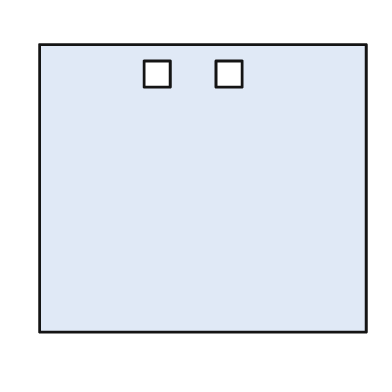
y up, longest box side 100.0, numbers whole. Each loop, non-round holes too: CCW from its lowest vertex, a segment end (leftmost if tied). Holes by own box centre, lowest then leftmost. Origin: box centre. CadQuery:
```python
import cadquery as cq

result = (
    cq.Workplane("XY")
    .moveTo(-50.0, -44.0)
    .lineTo(50.0, -44.0)
    .lineTo(50.0, 44.0)
    .lineTo(-50.0, 44.0)
    .close()
    .moveTo(-18.0, 31.0)
    .lineTo(-10.0, 31.0)
    .lineTo(-10.0, 39.0)
    .lineTo(-18.0, 39.0)
    .close()
    .moveTo(4.0, 31.0)
    .lineTo(12.0, 31.0)
    .lineTo(12.0, 39.0)
    .lineTo(4.0, 39.0)
    .close()
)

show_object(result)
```